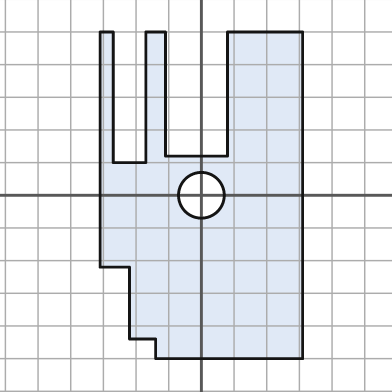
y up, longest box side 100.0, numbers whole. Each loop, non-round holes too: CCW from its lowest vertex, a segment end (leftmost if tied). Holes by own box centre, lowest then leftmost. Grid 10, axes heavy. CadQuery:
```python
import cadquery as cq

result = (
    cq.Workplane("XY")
    .moveTo(-14.0, -50.0)
    .lineTo(31.0, -50.0)
    .lineTo(31.0, 50.0)
    .lineTo(8.0, 50.0)
    .lineTo(8.0, 12.0)
    .lineTo(-11.0, 12.0)
    .lineTo(-11.0, 50.0)
    .lineTo(-17.0, 50.0)
    .lineTo(-17.0, 10.0)
    .lineTo(-27.0, 10.0)
    .lineTo(-27.0, 50.0)
    .lineTo(-31.0, 50.0)
    .lineTo(-31.0, -22.0)
    .lineTo(-22.0, -22.0)
    .lineTo(-22.0, -44.0)
    .lineTo(-14.0, -44.0)
    .close()
    .moveTo(0.0, 0.0)
    .circle(7.0)
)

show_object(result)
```